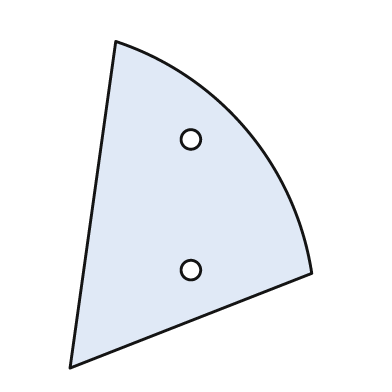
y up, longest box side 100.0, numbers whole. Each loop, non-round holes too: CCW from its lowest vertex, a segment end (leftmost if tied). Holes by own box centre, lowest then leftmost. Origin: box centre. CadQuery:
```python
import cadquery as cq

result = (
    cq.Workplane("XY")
    .moveTo(-37.0, -50.0)
    .lineTo(37.0, -21.0)
    .threePointArc((17.0, 23.0), (-23.0, 50.0))
    .close()
    .moveTo(0.0, -20.0)
    .circle(3.0)
    .moveTo(0.0, 20.0)
    .circle(3.0)
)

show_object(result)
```